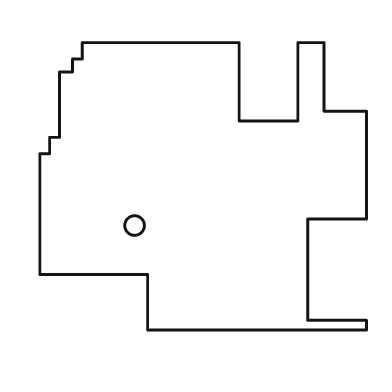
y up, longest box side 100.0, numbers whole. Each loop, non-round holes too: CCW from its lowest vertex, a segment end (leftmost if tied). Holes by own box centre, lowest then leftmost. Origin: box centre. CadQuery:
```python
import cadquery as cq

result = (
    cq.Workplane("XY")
    .moveTo(-17.0, -44.0)
    .lineTo(50.0, -44.0)
    .lineTo(50.0, -41.0)
    .lineTo(32.0, -41.0)
    .lineTo(32.0, -10.0)
    .lineTo(50.0, -10.0)
    .lineTo(50.0, 23.0)
    .lineTo(37.0, 23.0)
    .lineTo(37.0, 44.0)
    .lineTo(29.0, 44.0)
    .lineTo(29.0, 20.0)
    .lineTo(11.0, 20.0)
    .lineTo(11.0, 44.0)
    .lineTo(-37.0, 44.0)
    .lineTo(-37.0, 39.0)
    .lineTo(-40.0, 39.0)
    .lineTo(-40.0, 35.0)
    .lineTo(-44.0, 35.0)
    .lineTo(-44.0, 15.0)
    .lineTo(-47.0, 15.0)
    .lineTo(-47.0, 10.0)
    .lineTo(-50.0, 10.0)
    .lineTo(-50.0, -27.0)
    .lineTo(-17.0, -27.0)
    .close()
    .moveTo(-21.0, -12.0)
    .circle(3.0)
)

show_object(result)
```